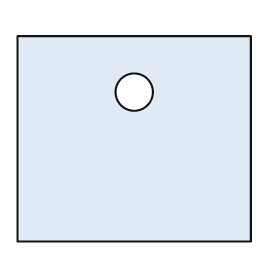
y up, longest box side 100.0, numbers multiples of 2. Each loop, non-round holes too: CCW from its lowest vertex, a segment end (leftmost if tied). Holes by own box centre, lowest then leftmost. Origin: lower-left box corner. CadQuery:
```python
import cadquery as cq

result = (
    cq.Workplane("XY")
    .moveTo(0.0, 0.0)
    .lineTo(100.0, 0.0)
    .lineTo(100.0, 88.0)
    .lineTo(0.0, 88.0)
    .close()
    .moveTo(50.0, 64.0)
    .circle(8.0)
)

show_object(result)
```